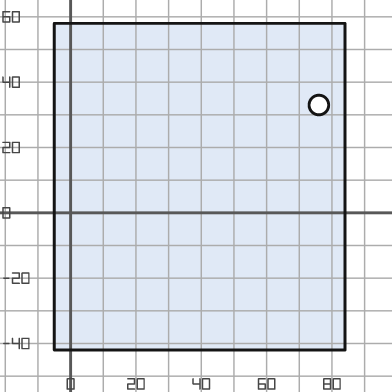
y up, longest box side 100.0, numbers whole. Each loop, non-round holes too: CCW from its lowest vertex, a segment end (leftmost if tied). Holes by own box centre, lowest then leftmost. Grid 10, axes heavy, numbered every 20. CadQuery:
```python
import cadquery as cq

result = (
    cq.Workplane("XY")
    .moveTo(-5.0, -42.0)
    .lineTo(84.0, -42.0)
    .lineTo(84.0, 58.0)
    .lineTo(-5.0, 58.0)
    .close()
    .moveTo(76.0, 33.0)
    .circle(3.0)
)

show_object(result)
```